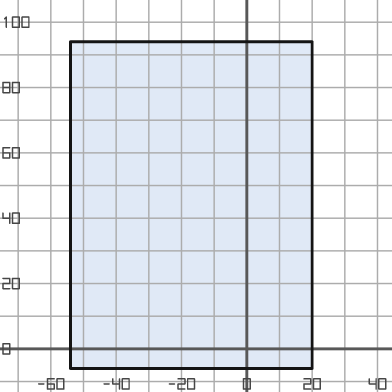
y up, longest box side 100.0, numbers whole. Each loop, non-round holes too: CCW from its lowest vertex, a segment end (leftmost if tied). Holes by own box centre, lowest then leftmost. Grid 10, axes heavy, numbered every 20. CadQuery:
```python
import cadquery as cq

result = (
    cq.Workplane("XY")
    .moveTo(-54.0, -6.0)
    .lineTo(20.0, -6.0)
    .lineTo(20.0, 94.0)
    .lineTo(-54.0, 94.0)
    .close()
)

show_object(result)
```